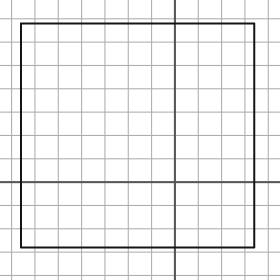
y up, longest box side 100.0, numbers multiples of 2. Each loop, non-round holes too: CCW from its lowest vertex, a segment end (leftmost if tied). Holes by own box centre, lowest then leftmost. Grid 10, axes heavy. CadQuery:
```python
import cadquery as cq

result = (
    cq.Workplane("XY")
    .moveTo(-66.0, -28.0)
    .lineTo(34.0, -28.0)
    .lineTo(34.0, 68.0)
    .lineTo(-66.0, 68.0)
    .close()
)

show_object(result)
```